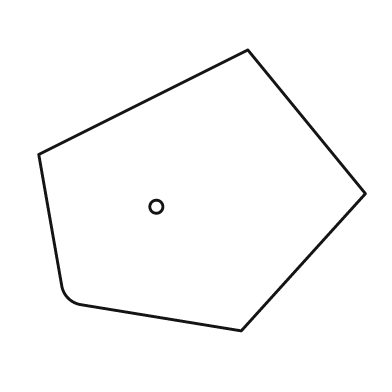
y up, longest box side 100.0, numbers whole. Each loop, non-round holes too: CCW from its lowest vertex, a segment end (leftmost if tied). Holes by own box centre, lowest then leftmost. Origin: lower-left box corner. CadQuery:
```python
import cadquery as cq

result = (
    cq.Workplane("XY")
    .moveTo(62.0, 0.0)
    .lineTo(100.0, 42.0)
    .lineTo(64.0, 86.0)
    .lineTo(0.0, 54.0)
    .lineTo(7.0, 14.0)
    .threePointArc((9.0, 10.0), (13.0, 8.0))
    .close()
    .moveTo(36.0, 38.0)
    .circle(2.0)
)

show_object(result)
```